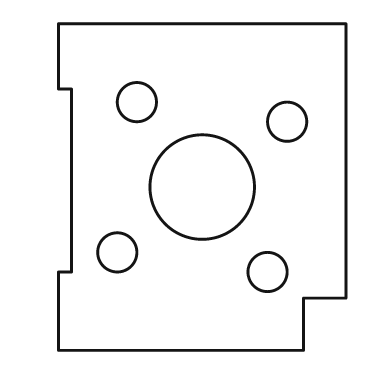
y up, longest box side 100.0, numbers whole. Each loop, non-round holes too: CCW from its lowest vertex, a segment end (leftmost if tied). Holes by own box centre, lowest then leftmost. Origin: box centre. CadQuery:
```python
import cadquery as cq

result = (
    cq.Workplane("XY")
    .moveTo(-44.0, -50.0)
    .lineTo(31.0, -50.0)
    .lineTo(31.0, -34.0)
    .lineTo(44.0, -34.0)
    .lineTo(44.0, 50.0)
    .lineTo(-44.0, 50.0)
    .lineTo(-44.0, 30.0)
    .lineTo(-40.0, 30.0)
    .lineTo(-40.0, -26.0)
    .lineTo(-44.0, -26.0)
    .close()
    .moveTo(20.0, -26.0)
    .circle(6.0)
    .moveTo(-26.0, -20.0)
    .circle(6.0)
    .moveTo(0.0, 0.0)
    .circle(16.0)
    .moveTo(26.0, 20.0)
    .circle(6.0)
    .moveTo(-20.0, 26.0)
    .circle(6.0)
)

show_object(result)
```